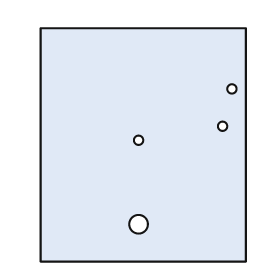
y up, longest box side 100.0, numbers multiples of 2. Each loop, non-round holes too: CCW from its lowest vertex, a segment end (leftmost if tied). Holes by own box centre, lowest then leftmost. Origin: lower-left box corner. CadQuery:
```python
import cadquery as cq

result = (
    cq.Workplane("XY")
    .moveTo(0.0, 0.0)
    .lineTo(88.0, 0.0)
    .lineTo(88.0, 100.0)
    .lineTo(0.0, 100.0)
    .close()
    .moveTo(42.0, 16.0)
    .circle(4.0)
    .moveTo(42.0, 52.0)
    .circle(2.0)
    .moveTo(78.0, 58.0)
    .circle(2.0)
    .moveTo(82.0, 74.0)
    .circle(2.0)
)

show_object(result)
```